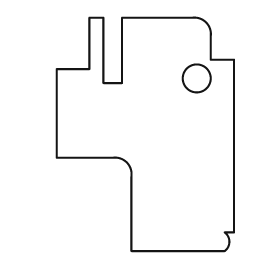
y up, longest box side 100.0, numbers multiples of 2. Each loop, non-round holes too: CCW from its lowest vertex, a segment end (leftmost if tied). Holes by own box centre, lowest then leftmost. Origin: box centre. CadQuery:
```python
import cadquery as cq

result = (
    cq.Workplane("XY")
    .moveTo(-6.0, -50.0)
    .lineTo(34.0, -50.0)
    .threePointArc((36.0, -46.0), (34.0, -42.0))
    .lineTo(38.0, -42.0)
    .lineTo(38.0, 32.0)
    .lineTo(28.0, 32.0)
    .lineTo(28.0, 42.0)
    .threePointArc((26.0, 48.0), (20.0, 50.0))
    .lineTo(-10.0, 50.0)
    .lineTo(-10.0, 22.0)
    .lineTo(-18.0, 22.0)
    .lineTo(-18.0, 50.0)
    .lineTo(-24.0, 50.0)
    .lineTo(-24.0, 28.0)
    .lineTo(-38.0, 28.0)
    .lineTo(-38.0, -10.0)
    .lineTo(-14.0, -10.0)
    .threePointArc((-8.0, -12.0), (-6.0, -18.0))
    .close()
    .moveTo(22.0, 24.0)
    .circle(6.0)
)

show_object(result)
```